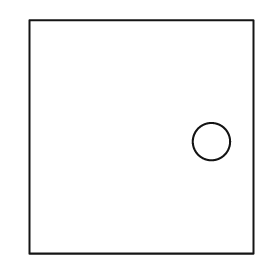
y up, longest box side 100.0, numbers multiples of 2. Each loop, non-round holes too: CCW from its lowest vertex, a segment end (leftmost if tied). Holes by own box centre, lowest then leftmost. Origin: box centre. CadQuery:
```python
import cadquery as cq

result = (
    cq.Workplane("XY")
    .moveTo(-48.0, -50.0)
    .lineTo(48.0, -50.0)
    .lineTo(48.0, 50.0)
    .lineTo(-48.0, 50.0)
    .close()
    .moveTo(30.0, -2.0)
    .circle(8.0)
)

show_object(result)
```